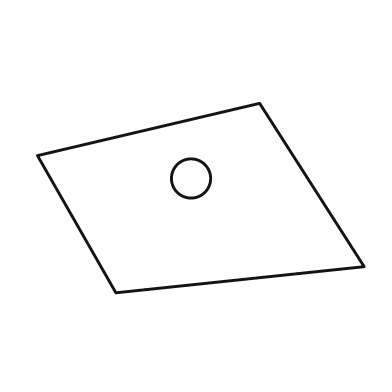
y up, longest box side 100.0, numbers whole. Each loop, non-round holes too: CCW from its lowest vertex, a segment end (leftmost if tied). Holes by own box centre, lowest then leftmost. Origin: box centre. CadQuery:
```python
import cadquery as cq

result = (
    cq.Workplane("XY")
    .moveTo(-26.0, -29.0)
    .lineTo(50.0, -21.0)
    .lineTo(18.0, 29.0)
    .lineTo(-50.0, 13.0)
    .close()
    .moveTo(-3.0, 6.0)
    .circle(6.0)
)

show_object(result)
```